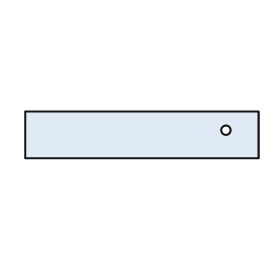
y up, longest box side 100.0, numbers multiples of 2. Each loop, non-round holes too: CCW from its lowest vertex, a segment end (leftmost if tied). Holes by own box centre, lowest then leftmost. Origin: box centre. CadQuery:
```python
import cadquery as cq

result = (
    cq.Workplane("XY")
    .moveTo(-50.0, -10.0)
    .lineTo(50.0, -10.0)
    .lineTo(50.0, 10.0)
    .lineTo(-50.0, 10.0)
    .close()
    .moveTo(36.0, 2.0)
    .circle(2.0)
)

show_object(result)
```